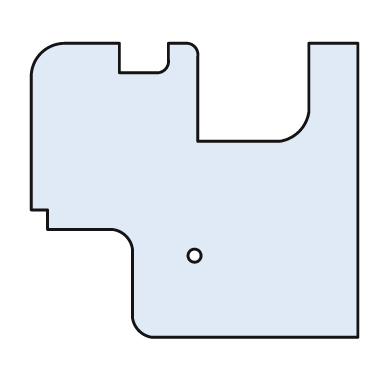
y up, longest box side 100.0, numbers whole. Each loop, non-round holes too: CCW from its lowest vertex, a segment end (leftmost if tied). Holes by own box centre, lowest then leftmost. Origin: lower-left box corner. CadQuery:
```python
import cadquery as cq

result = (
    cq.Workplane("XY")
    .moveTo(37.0, 0.0)
    .lineTo(100.0, 0.0)
    .lineTo(100.0, 90.0)
    .lineTo(85.0, 90.0)
    .lineTo(85.0, 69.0)
    .threePointArc((82.0, 63.0), (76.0, 60.0))
    .lineTo(51.0, 60.0)
    .lineTo(51.0, 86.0)
    .threePointArc((50.0, 89.0), (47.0, 90.0))
    .lineTo(42.0, 90.0)
    .lineTo(42.0, 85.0)
    .threePointArc((41.0, 82.0), (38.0, 81.0))
    .lineTo(27.0, 81.0)
    .lineTo(27.0, 90.0)
    .lineTo(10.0, 90.0)
    .threePointArc((3.0, 87.0), (0.0, 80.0))
    .lineTo(0.0, 39.0)
    .lineTo(5.0, 39.0)
    .lineTo(5.0, 33.0)
    .lineTo(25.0, 33.0)
    .threePointArc((29.0, 31.0), (31.0, 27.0))
    .lineTo(31.0, 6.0)
    .threePointArc((33.0, 2.0), (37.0, 0.0))
    .close()
    .moveTo(50.0, 25.0)
    .circle(2.0)
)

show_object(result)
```